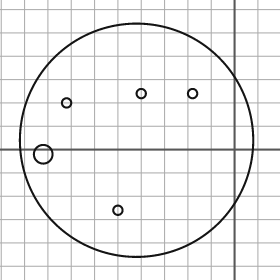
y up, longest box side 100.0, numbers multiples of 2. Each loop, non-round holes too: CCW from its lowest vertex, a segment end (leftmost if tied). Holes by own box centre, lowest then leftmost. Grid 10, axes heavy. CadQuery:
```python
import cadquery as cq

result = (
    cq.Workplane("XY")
    .moveTo(-42.0, 4.0)
    .circle(50.0)
    .moveTo(-50.0, -26.0)
    .circle(2.0)
    .moveTo(-82.0, -2.0)
    .circle(4.0)
    .moveTo(-72.0, 20.0)
    .circle(2.0)
    .moveTo(-40.0, 24.0)
    .circle(2.0)
    .moveTo(-18.0, 24.0)
    .circle(2.0)
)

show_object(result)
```